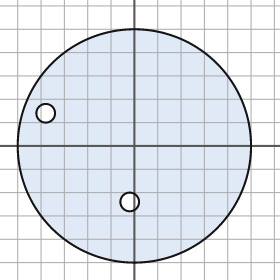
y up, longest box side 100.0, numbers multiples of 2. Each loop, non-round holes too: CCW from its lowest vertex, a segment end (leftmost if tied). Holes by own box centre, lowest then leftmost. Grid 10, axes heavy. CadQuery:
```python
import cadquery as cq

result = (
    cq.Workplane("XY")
    .moveTo(0.0, 0.0)
    .circle(50.0)
    .moveTo(-2.0, -24.0)
    .circle(4.0)
    .moveTo(-38.0, 14.0)
    .circle(4.0)
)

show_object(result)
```